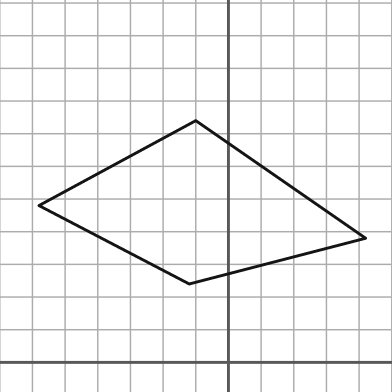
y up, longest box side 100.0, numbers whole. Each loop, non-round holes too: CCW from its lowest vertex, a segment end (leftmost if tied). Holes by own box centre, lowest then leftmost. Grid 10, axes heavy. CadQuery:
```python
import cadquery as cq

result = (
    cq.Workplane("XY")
    .moveTo(-12.0, 24.0)
    .lineTo(42.0, 38.0)
    .lineTo(-10.0, 74.0)
    .lineTo(-58.0, 48.0)
    .close()
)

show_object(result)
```